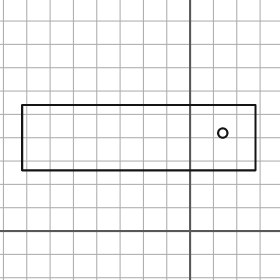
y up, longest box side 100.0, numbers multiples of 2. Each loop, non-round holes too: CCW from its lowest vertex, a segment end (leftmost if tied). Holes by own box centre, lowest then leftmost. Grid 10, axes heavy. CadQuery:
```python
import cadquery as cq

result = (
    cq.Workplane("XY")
    .moveTo(-72.0, 26.0)
    .lineTo(28.0, 26.0)
    .lineTo(28.0, 54.0)
    .lineTo(-72.0, 54.0)
    .close()
    .moveTo(14.0, 42.0)
    .circle(2.0)
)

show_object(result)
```